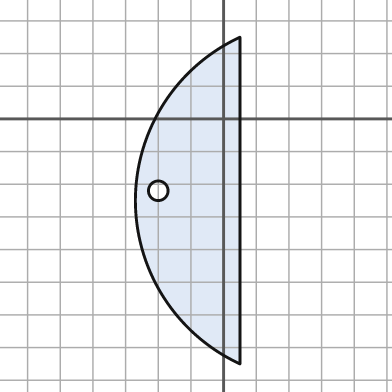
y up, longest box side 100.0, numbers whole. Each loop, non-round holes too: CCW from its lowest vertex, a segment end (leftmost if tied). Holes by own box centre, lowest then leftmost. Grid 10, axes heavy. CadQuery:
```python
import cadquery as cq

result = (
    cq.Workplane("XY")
    .moveTo(5.0, -75.0)
    .lineTo(5.0, 25.0)
    .threePointArc((-27.0, -25.0), (5.0, -75.0))
    .close()
    .moveTo(-20.0, -22.0)
    .circle(3.0)
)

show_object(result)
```